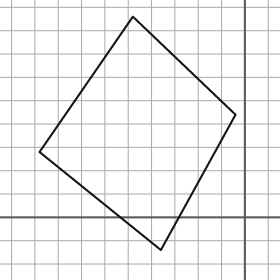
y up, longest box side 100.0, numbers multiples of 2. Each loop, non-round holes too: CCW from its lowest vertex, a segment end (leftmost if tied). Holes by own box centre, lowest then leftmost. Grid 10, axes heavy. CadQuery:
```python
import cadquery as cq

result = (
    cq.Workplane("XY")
    .moveTo(-36.0, -14.0)
    .lineTo(-4.0, 44.0)
    .lineTo(-48.0, 86.0)
    .lineTo(-88.0, 28.0)
    .close()
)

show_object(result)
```